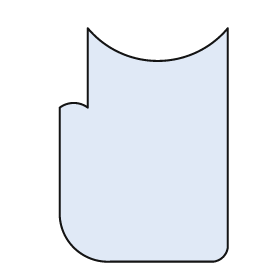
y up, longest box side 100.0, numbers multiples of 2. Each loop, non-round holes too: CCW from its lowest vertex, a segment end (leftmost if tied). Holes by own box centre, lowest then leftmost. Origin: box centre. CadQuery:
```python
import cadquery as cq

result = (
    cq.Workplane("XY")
    .moveTo(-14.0, -50.0)
    .lineTo(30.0, -50.0)
    .threePointArc((34.0, -48.0), (36.0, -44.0))
    .lineTo(36.0, 50.0)
    .threePointArc((6.0, 36.0), (-24.0, 50.0))
    .lineTo(-24.0, 16.0)
    .threePointArc((-30.0, 18.0), (-36.0, 16.0))
    .lineTo(-36.0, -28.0)
    .threePointArc((-30.0, -44.0), (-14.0, -50.0))
    .close()
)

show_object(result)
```